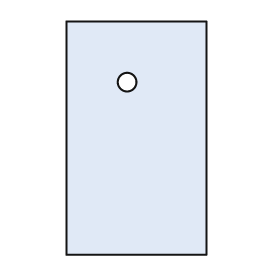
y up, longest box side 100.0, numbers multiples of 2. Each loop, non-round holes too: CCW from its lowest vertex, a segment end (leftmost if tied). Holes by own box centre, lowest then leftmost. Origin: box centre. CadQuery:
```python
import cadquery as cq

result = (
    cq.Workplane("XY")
    .moveTo(-30.0, -50.0)
    .lineTo(30.0, -50.0)
    .lineTo(30.0, 50.0)
    .lineTo(-30.0, 50.0)
    .close()
    .moveTo(-4.0, 24.0)
    .circle(4.0)
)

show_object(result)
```